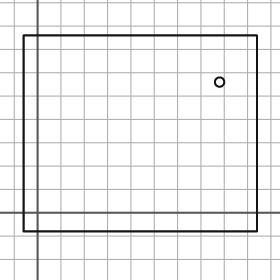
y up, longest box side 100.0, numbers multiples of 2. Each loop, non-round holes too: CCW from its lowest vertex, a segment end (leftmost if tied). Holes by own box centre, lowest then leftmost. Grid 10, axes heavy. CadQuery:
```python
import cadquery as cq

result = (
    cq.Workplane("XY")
    .moveTo(-6.0, -8.0)
    .lineTo(94.0, -8.0)
    .lineTo(94.0, 76.0)
    .lineTo(-6.0, 76.0)
    .close()
    .moveTo(78.0, 56.0)
    .circle(2.0)
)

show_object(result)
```